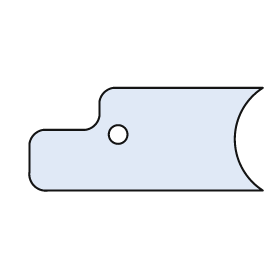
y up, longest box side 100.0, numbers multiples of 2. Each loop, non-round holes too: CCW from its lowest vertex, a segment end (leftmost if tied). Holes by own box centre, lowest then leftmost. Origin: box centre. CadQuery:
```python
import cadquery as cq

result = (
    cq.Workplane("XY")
    .moveTo(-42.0, -22.0)
    .lineTo(50.0, -22.0)
    .threePointArc((38.0, 0.0), (50.0, 22.0))
    .lineTo(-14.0, 22.0)
    .threePointArc((-18.0, 20.0), (-20.0, 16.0))
    .lineTo(-20.0, 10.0)
    .threePointArc((-22.0, 6.0), (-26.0, 4.0))
    .lineTo(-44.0, 4.0)
    .threePointArc((-48.0, 2.0), (-50.0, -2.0))
    .lineTo(-50.0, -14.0)
    .threePointArc((-48.0, -20.0), (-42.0, -22.0))
    .close()
    .moveTo(-12.0, 2.0)
    .circle(4.0)
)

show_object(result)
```